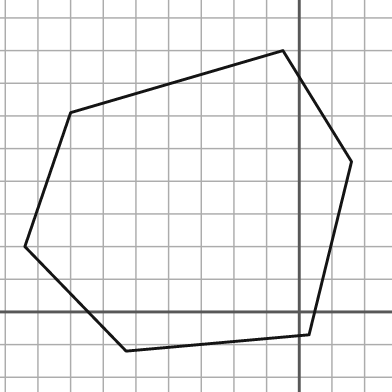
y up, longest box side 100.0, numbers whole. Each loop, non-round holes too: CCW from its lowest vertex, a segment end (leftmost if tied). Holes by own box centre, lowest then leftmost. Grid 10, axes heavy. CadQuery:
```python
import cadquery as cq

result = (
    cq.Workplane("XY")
    .moveTo(-53.0, -12.0)
    .lineTo(3.0, -7.0)
    .lineTo(16.0, 46.0)
    .lineTo(-5.0, 80.0)
    .lineTo(-70.0, 61.0)
    .lineTo(-84.0, 20.0)
    .close()
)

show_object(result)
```